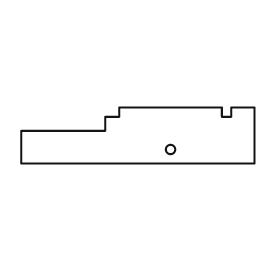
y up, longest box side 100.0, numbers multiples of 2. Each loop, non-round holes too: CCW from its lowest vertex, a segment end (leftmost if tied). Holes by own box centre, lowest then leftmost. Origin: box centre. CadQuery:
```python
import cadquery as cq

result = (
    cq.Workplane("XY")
    .moveTo(-50.0, -12.0)
    .lineTo(50.0, -12.0)
    .lineTo(50.0, 12.0)
    .lineTo(40.0, 12.0)
    .lineTo(40.0, 8.0)
    .lineTo(36.0, 8.0)
    .lineTo(36.0, 12.0)
    .lineTo(-8.0, 12.0)
    .lineTo(-8.0, 8.0)
    .lineTo(-14.0, 8.0)
    .lineTo(-14.0, 2.0)
    .lineTo(-50.0, 2.0)
    .close()
    .moveTo(14.0, -6.0)
    .circle(2.0)
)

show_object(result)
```